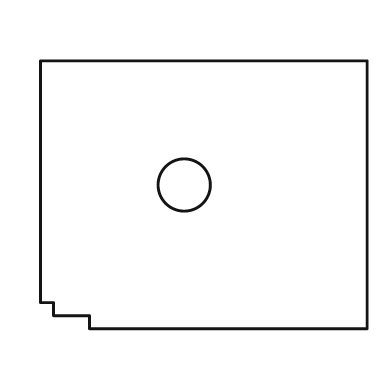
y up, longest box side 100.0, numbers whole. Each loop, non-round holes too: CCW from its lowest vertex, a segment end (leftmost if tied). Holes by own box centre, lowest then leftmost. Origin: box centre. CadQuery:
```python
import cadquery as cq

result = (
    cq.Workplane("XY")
    .moveTo(-35.0, -41.0)
    .lineTo(50.0, -41.0)
    .lineTo(50.0, 41.0)
    .lineTo(-50.0, 41.0)
    .lineTo(-50.0, -33.0)
    .lineTo(-46.0, -33.0)
    .lineTo(-46.0, -37.0)
    .lineTo(-35.0, -37.0)
    .close()
    .moveTo(-6.0, 3.0)
    .circle(8.0)
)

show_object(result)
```